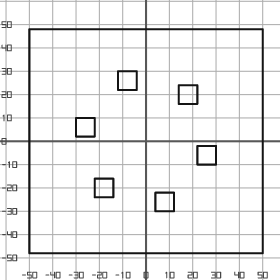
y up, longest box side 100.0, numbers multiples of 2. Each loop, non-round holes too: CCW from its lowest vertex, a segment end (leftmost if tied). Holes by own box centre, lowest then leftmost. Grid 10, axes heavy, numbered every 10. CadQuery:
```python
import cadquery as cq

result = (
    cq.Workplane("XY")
    .moveTo(-50.0, -48.0)
    .lineTo(50.0, -48.0)
    .lineTo(50.0, 48.0)
    .lineTo(-50.0, 48.0)
    .close()
    .moveTo(4.0, -30.0)
    .lineTo(12.0, -30.0)
    .lineTo(12.0, -22.0)
    .lineTo(4.0, -22.0)
    .close()
    .moveTo(-22.0, -24.0)
    .lineTo(-14.0, -24.0)
    .lineTo(-14.0, -16.0)
    .lineTo(-22.0, -16.0)
    .close()
    .moveTo(22.0, -10.0)
    .lineTo(30.0, -10.0)
    .lineTo(30.0, -2.0)
    .lineTo(22.0, -2.0)
    .close()
    .moveTo(-30.0, 2.0)
    .lineTo(-22.0, 2.0)
    .lineTo(-22.0, 10.0)
    .lineTo(-30.0, 10.0)
    .close()
    .moveTo(14.0, 16.0)
    .lineTo(22.0, 16.0)
    .lineTo(22.0, 24.0)
    .lineTo(14.0, 24.0)
    .close()
    .moveTo(-12.0, 22.0)
    .lineTo(-4.0, 22.0)
    .lineTo(-4.0, 30.0)
    .lineTo(-12.0, 30.0)
    .close()
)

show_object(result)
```